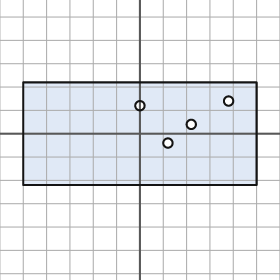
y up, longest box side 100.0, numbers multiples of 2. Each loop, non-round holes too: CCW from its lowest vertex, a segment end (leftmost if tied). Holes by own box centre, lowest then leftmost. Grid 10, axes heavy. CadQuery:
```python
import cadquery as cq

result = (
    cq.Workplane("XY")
    .moveTo(-50.0, -22.0)
    .lineTo(50.0, -22.0)
    .lineTo(50.0, 22.0)
    .lineTo(-50.0, 22.0)
    .close()
    .moveTo(12.0, -4.0)
    .circle(2.0)
    .moveTo(22.0, 4.0)
    .circle(2.0)
    .moveTo(0.0, 12.0)
    .circle(2.0)
    .moveTo(38.0, 14.0)
    .circle(2.0)
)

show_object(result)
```